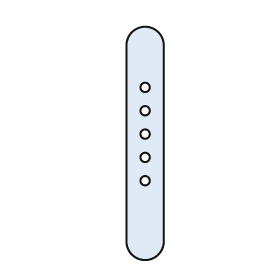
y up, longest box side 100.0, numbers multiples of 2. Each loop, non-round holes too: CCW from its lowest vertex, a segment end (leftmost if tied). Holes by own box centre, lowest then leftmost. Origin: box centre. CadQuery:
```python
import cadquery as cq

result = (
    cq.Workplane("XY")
    .moveTo(-8.0, -42.0)
    .threePointArc((0.0, -50.0), (8.0, -42.0))
    .lineTo(8.0, 42.0)
    .threePointArc((0.0, 50.0), (-8.0, 42.0))
    .close()
    .moveTo(0.0, -16.0)
    .circle(2.0)
    .moveTo(0.0, -6.0)
    .circle(2.0)
    .moveTo(0.0, 4.0)
    .circle(2.0)
    .moveTo(0.0, 14.0)
    .circle(2.0)
    .moveTo(0.0, 24.0)
    .circle(2.0)
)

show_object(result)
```